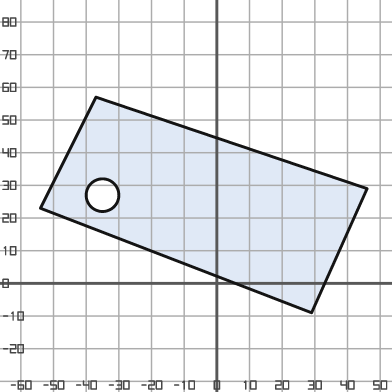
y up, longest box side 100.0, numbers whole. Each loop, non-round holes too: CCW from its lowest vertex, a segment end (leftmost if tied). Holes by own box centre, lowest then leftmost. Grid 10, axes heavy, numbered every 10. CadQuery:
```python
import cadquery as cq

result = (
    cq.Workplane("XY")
    .moveTo(29.0, -9.0)
    .lineTo(46.0, 29.0)
    .lineTo(-37.0, 57.0)
    .lineTo(-54.0, 23.0)
    .close()
    .moveTo(-35.0, 27.0)
    .circle(5.0)
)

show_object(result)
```